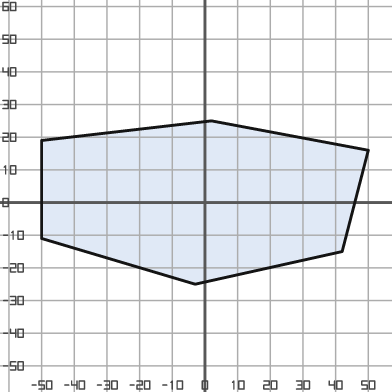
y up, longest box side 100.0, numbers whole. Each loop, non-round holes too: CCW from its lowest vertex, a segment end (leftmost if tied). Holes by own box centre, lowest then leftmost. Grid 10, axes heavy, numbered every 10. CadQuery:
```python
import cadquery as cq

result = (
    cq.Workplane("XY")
    .moveTo(-3.0, -25.0)
    .lineTo(42.0, -15.0)
    .lineTo(50.0, 16.0)
    .lineTo(2.0, 25.0)
    .lineTo(-50.0, 19.0)
    .lineTo(-50.0, -11.0)
    .close()
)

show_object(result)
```